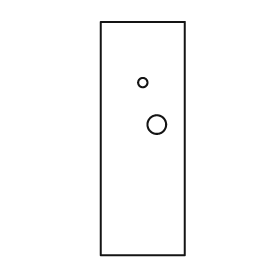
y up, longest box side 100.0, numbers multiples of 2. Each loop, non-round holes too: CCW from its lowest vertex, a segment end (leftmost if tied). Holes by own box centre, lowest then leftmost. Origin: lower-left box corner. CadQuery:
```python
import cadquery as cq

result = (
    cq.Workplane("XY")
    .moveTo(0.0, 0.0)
    .lineTo(36.0, 0.0)
    .lineTo(36.0, 100.0)
    .lineTo(0.0, 100.0)
    .close()
    .moveTo(24.0, 56.0)
    .circle(4.0)
    .moveTo(18.0, 74.0)
    .circle(2.0)
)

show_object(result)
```